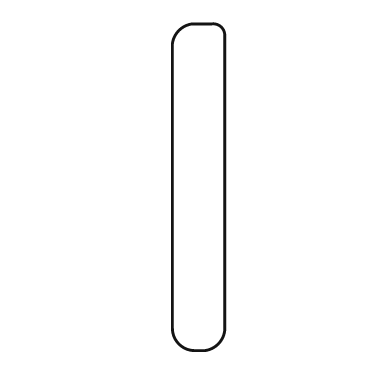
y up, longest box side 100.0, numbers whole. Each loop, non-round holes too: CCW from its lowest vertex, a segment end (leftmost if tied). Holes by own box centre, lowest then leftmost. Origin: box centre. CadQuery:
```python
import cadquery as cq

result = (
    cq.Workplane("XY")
    .moveTo(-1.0, -50.0)
    .lineTo(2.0, -50.0)
    .threePointArc((6.0, -48.0), (8.0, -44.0))
    .lineTo(8.0, 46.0)
    .threePointArc((7.0, 49.0), (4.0, 50.0))
    .lineTo(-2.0, 50.0)
    .threePointArc((-6.0, 48.0), (-8.0, 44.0))
    .lineTo(-8.0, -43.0)
    .threePointArc((-6.0, -48.0), (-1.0, -50.0))
    .close()
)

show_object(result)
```